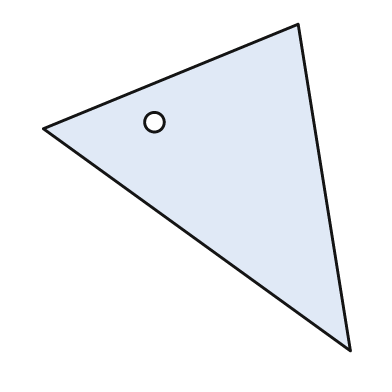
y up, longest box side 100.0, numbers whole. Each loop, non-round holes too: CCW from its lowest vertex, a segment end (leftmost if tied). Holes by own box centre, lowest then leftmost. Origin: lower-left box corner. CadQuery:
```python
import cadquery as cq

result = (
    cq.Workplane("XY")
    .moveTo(94.0, 0.0)
    .lineTo(78.0, 100.0)
    .lineTo(0.0, 68.0)
    .close()
    .moveTo(34.0, 70.0)
    .circle(3.0)
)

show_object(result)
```